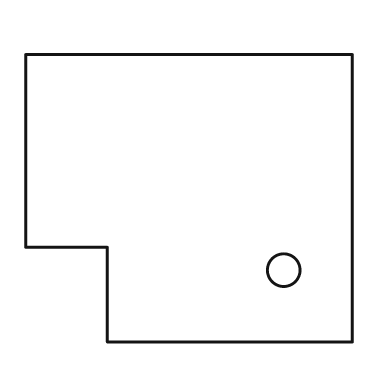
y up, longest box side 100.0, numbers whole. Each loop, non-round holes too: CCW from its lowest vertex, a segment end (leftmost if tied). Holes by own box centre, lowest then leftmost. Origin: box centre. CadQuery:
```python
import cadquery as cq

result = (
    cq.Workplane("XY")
    .moveTo(-25.0, -44.0)
    .lineTo(50.0, -44.0)
    .lineTo(50.0, 44.0)
    .lineTo(-50.0, 44.0)
    .lineTo(-50.0, -15.0)
    .lineTo(-25.0, -15.0)
    .close()
    .moveTo(29.0, -22.0)
    .circle(5.0)
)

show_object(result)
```